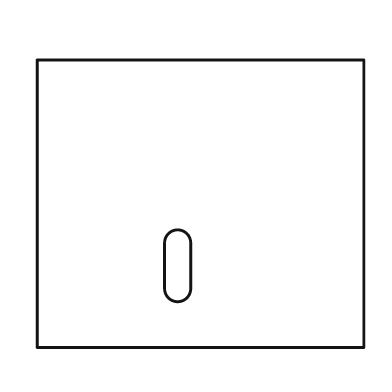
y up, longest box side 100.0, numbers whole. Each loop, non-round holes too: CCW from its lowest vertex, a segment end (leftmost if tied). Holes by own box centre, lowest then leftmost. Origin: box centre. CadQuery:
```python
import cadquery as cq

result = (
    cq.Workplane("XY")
    .moveTo(-50.0, -44.0)
    .lineTo(50.0, -44.0)
    .lineTo(50.0, 44.0)
    .lineTo(-50.0, 44.0)
    .close()
    .moveTo(-11.0, -26.0)
    .threePointArc((-7.0, -30.0), (-3.0, -26.0))
    .lineTo(-3.0, -12.0)
    .threePointArc((-7.0, -8.0), (-11.0, -12.0))
    .close()
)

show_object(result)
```